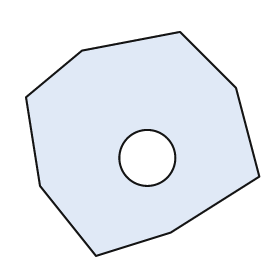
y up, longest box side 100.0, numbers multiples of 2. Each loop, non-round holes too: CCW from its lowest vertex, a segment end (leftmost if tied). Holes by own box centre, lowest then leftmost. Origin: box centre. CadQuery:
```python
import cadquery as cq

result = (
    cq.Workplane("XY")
    .moveTo(-20.0, -48.0)
    .lineTo(12.0, -38.0)
    .lineTo(50.0, -14.0)
    .lineTo(40.0, 24.0)
    .lineTo(16.0, 48.0)
    .lineTo(-26.0, 40.0)
    .lineTo(-50.0, 20.0)
    .lineTo(-44.0, -18.0)
    .close()
    .moveTo(2.0, -6.0)
    .circle(12.0)
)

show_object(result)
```